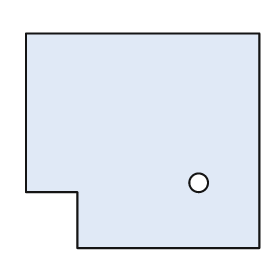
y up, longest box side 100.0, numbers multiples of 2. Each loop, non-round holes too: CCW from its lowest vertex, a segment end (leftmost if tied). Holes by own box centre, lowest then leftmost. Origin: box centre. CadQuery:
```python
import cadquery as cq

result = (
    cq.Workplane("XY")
    .moveTo(-28.0, -46.0)
    .lineTo(50.0, -46.0)
    .lineTo(50.0, 46.0)
    .lineTo(-50.0, 46.0)
    .lineTo(-50.0, -22.0)
    .lineTo(-28.0, -22.0)
    .close()
    .moveTo(24.0, -18.0)
    .circle(4.0)
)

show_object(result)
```